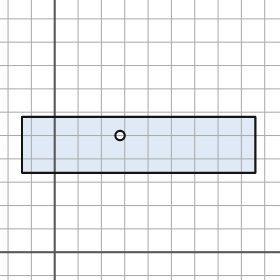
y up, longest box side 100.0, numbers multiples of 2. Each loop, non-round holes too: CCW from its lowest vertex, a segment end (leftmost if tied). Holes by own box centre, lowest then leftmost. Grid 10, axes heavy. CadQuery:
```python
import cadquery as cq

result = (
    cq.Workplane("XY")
    .moveTo(-14.0, 34.0)
    .lineTo(86.0, 34.0)
    .lineTo(86.0, 58.0)
    .lineTo(-14.0, 58.0)
    .close()
    .moveTo(28.0, 50.0)
    .circle(2.0)
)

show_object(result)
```